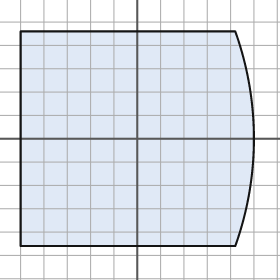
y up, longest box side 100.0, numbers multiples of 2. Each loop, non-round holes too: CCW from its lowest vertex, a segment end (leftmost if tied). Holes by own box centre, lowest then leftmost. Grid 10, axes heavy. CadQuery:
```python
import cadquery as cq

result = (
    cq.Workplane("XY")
    .moveTo(-50.0, -46.0)
    .lineTo(42.0, -46.0)
    .threePointArc((50.0, 0.0), (42.0, 46.0))
    .lineTo(-50.0, 46.0)
    .close()
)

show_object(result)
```